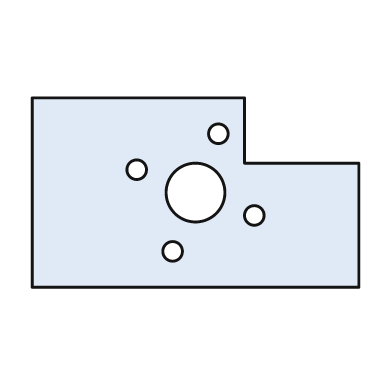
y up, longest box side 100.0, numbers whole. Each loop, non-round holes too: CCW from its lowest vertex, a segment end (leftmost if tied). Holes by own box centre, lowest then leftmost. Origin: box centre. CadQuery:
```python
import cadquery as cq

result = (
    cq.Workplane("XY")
    .moveTo(-50.0, -29.0)
    .lineTo(50.0, -29.0)
    .lineTo(50.0, 9.0)
    .lineTo(15.0, 9.0)
    .lineTo(15.0, 29.0)
    .lineTo(-50.0, 29.0)
    .close()
    .moveTo(-7.0, -18.0)
    .circle(3.0)
    .moveTo(18.0, -7.0)
    .circle(3.0)
    .moveTo(0.0, 0.0)
    .circle(9.0)
    .moveTo(-18.0, 7.0)
    .circle(3.0)
    .moveTo(7.0, 18.0)
    .circle(3.0)
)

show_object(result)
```